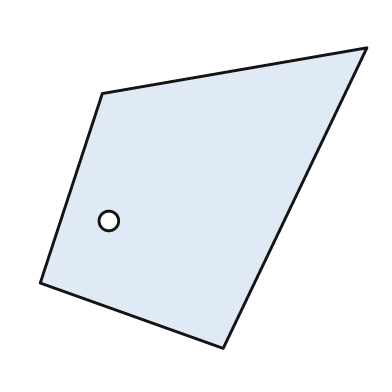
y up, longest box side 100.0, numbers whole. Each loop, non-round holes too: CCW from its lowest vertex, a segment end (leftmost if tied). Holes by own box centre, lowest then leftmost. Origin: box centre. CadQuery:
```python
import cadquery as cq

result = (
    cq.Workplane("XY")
    .moveTo(6.0, -46.0)
    .lineTo(50.0, 46.0)
    .lineTo(-31.0, 32.0)
    .lineTo(-50.0, -26.0)
    .close()
    .moveTo(-29.0, -7.0)
    .circle(3.0)
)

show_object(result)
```